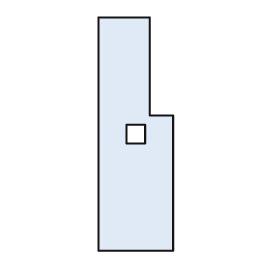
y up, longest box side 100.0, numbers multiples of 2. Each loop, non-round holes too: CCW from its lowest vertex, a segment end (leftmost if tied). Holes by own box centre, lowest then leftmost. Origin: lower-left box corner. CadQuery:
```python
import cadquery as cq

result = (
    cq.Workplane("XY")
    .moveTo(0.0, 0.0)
    .lineTo(32.0, 0.0)
    .lineTo(32.0, 58.0)
    .lineTo(22.0, 58.0)
    .lineTo(22.0, 100.0)
    .lineTo(0.0, 100.0)
    .close()
    .moveTo(12.0, 46.0)
    .lineTo(20.0, 46.0)
    .lineTo(20.0, 54.0)
    .lineTo(12.0, 54.0)
    .close()
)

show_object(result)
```